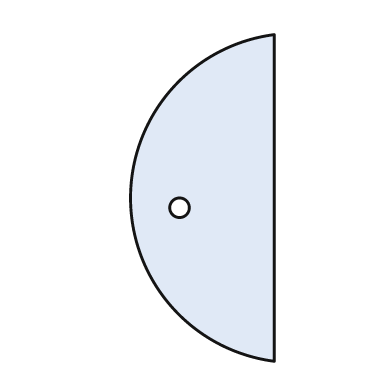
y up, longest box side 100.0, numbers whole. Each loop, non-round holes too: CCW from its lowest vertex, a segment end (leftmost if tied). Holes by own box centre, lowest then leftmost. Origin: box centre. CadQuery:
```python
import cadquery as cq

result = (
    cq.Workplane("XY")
    .moveTo(22.0, -50.0)
    .lineTo(22.0, 50.0)
    .threePointArc((-22.0, 0.0), (22.0, -50.0))
    .close()
    .moveTo(-7.0, -3.0)
    .circle(3.0)
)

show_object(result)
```